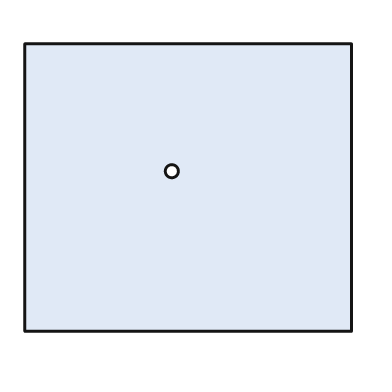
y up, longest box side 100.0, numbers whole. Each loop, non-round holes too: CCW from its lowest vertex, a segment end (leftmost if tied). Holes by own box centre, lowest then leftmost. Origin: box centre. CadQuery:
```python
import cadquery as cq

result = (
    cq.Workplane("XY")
    .moveTo(-50.0, -44.0)
    .lineTo(50.0, -44.0)
    .lineTo(50.0, 44.0)
    .lineTo(-50.0, 44.0)
    .close()
    .moveTo(-5.0, 5.0)
    .circle(2.0)
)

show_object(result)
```